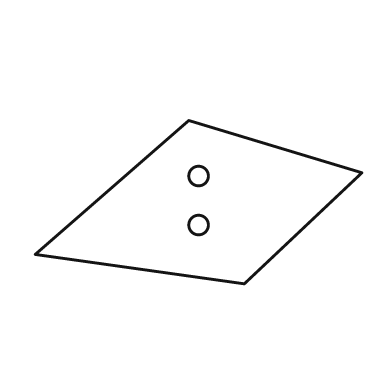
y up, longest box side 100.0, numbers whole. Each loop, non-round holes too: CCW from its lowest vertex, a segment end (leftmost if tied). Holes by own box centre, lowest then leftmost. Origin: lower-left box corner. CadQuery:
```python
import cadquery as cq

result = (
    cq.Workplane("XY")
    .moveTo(64.0, 0.0)
    .lineTo(100.0, 34.0)
    .lineTo(47.0, 50.0)
    .lineTo(0.0, 9.0)
    .close()
    .moveTo(50.0, 18.0)
    .circle(3.0)
    .moveTo(50.0, 33.0)
    .circle(3.0)
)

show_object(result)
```